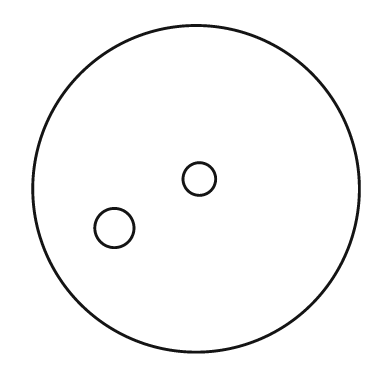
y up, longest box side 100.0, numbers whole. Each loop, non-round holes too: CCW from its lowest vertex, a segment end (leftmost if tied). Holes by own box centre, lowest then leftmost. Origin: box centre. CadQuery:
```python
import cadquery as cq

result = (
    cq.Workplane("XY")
    .moveTo(0.0, 0.0)
    .circle(50.0)
    .moveTo(-25.0, -12.0)
    .circle(6.0)
    .moveTo(1.0, 3.0)
    .circle(5.0)
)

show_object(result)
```